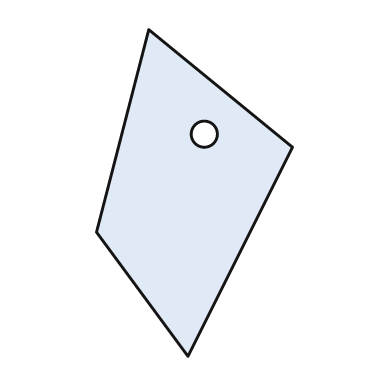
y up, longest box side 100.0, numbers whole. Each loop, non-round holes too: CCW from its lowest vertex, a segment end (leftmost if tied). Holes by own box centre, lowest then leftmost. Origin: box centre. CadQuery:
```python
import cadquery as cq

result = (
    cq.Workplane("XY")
    .moveTo(-2.0, -50.0)
    .lineTo(30.0, 14.0)
    .lineTo(-14.0, 50.0)
    .lineTo(-30.0, -12.0)
    .close()
    .moveTo(3.0, 18.0)
    .circle(4.0)
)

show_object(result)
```